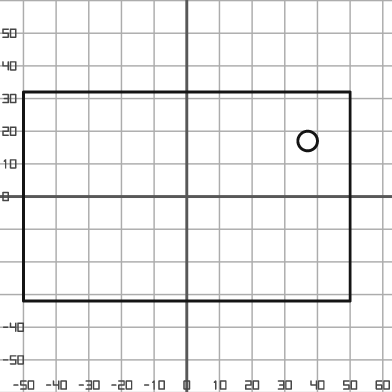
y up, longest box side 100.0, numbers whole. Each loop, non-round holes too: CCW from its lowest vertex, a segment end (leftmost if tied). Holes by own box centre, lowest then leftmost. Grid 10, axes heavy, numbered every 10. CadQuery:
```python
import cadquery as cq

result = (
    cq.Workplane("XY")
    .moveTo(-50.0, -32.0)
    .lineTo(50.0, -32.0)
    .lineTo(50.0, 32.0)
    .lineTo(-50.0, 32.0)
    .close()
    .moveTo(37.0, 17.0)
    .circle(3.0)
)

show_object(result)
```